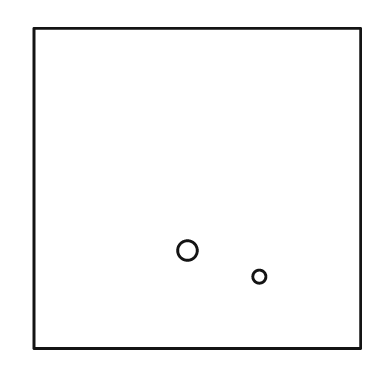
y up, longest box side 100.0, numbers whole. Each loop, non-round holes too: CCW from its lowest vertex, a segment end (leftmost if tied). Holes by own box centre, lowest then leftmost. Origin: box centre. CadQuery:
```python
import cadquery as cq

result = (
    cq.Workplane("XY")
    .moveTo(-50.0, -49.0)
    .lineTo(50.0, -49.0)
    .lineTo(50.0, 49.0)
    .lineTo(-50.0, 49.0)
    .close()
    .moveTo(19.0, -27.0)
    .circle(2.0)
    .moveTo(-3.0, -19.0)
    .circle(3.0)
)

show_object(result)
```